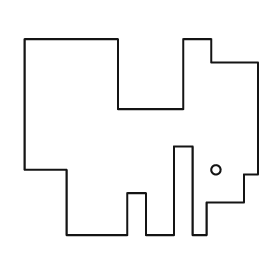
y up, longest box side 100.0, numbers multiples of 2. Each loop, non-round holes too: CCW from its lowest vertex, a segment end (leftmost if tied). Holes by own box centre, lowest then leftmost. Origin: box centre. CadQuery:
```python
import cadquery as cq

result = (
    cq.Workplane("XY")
    .moveTo(-32.0, -42.0)
    .lineTo(-6.0, -42.0)
    .lineTo(-6.0, -24.0)
    .lineTo(2.0, -24.0)
    .lineTo(2.0, -42.0)
    .lineTo(14.0, -42.0)
    .lineTo(14.0, -4.0)
    .lineTo(22.0, -4.0)
    .lineTo(22.0, -42.0)
    .lineTo(28.0, -42.0)
    .lineTo(28.0, -28.0)
    .lineTo(44.0, -28.0)
    .lineTo(44.0, -16.0)
    .lineTo(50.0, -16.0)
    .lineTo(50.0, 32.0)
    .lineTo(30.0, 32.0)
    .lineTo(30.0, 42.0)
    .lineTo(18.0, 42.0)
    .lineTo(18.0, 12.0)
    .lineTo(-10.0, 12.0)
    .lineTo(-10.0, 42.0)
    .lineTo(-50.0, 42.0)
    .lineTo(-50.0, -14.0)
    .lineTo(-32.0, -14.0)
    .close()
    .moveTo(32.0, -14.0)
    .circle(2.0)
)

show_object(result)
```